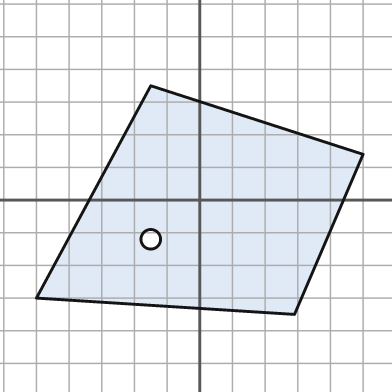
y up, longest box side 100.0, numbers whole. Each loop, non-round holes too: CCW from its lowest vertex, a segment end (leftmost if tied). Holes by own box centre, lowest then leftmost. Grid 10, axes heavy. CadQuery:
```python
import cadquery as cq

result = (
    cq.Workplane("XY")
    .moveTo(29.0, -35.0)
    .lineTo(50.0, 14.0)
    .lineTo(-15.0, 35.0)
    .lineTo(-50.0, -30.0)
    .close()
    .moveTo(-15.0, -12.0)
    .circle(3.0)
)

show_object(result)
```